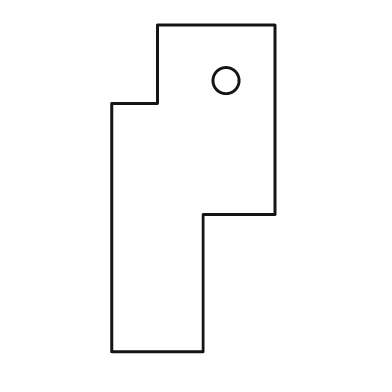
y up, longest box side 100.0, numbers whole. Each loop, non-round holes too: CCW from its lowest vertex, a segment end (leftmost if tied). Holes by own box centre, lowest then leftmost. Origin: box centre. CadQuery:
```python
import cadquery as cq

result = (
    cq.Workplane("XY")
    .moveTo(-25.0, -50.0)
    .lineTo(3.0, -50.0)
    .lineTo(3.0, -8.0)
    .lineTo(25.0, -8.0)
    .lineTo(25.0, 50.0)
    .lineTo(-11.0, 50.0)
    .lineTo(-11.0, 26.0)
    .lineTo(-25.0, 26.0)
    .close()
    .moveTo(10.0, 33.0)
    .circle(4.0)
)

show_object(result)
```